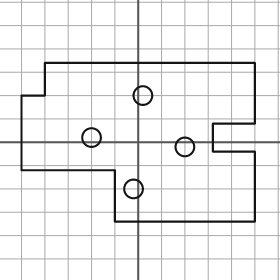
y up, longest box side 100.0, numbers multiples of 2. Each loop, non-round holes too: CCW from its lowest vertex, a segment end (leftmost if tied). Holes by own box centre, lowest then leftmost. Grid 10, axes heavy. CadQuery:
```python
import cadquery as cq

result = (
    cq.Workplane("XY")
    .moveTo(-10.0, -34.0)
    .lineTo(50.0, -34.0)
    .lineTo(50.0, -4.0)
    .lineTo(32.0, -4.0)
    .lineTo(32.0, 8.0)
    .lineTo(50.0, 8.0)
    .lineTo(50.0, 34.0)
    .lineTo(-40.0, 34.0)
    .lineTo(-40.0, 20.0)
    .lineTo(-50.0, 20.0)
    .lineTo(-50.0, -12.0)
    .lineTo(-10.0, -12.0)
    .close()
    .moveTo(-2.0, -20.0)
    .circle(4.0)
    .moveTo(20.0, -2.0)
    .circle(4.0)
    .moveTo(-20.0, 2.0)
    .circle(4.0)
    .moveTo(2.0, 20.0)
    .circle(4.0)
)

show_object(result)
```